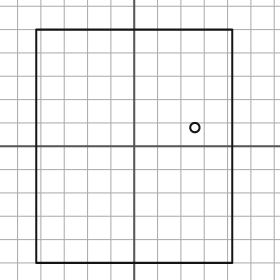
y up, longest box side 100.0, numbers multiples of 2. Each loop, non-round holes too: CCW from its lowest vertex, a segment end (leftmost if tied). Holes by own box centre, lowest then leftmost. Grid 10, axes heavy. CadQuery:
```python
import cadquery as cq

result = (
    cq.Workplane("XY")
    .moveTo(-42.0, -50.0)
    .lineTo(42.0, -50.0)
    .lineTo(42.0, 50.0)
    .lineTo(-42.0, 50.0)
    .close()
    .moveTo(26.0, 8.0)
    .circle(2.0)
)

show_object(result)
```